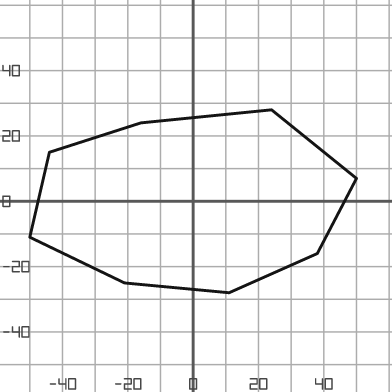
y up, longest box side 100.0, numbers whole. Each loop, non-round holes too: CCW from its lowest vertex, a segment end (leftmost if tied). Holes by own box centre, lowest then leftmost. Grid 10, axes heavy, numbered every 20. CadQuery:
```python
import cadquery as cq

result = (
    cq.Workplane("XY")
    .moveTo(11.0, -28.0)
    .lineTo(38.0, -16.0)
    .lineTo(50.0, 7.0)
    .lineTo(24.0, 28.0)
    .lineTo(-16.0, 24.0)
    .lineTo(-44.0, 15.0)
    .lineTo(-50.0, -11.0)
    .lineTo(-21.0, -25.0)
    .close()
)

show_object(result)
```